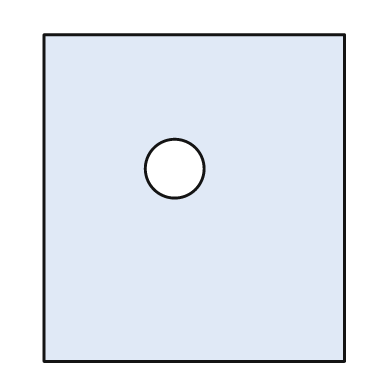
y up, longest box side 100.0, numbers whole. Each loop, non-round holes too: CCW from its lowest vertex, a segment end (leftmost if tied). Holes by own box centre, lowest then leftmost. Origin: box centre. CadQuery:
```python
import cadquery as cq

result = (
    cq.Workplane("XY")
    .moveTo(-46.0, -50.0)
    .lineTo(46.0, -50.0)
    .lineTo(46.0, 50.0)
    .lineTo(-46.0, 50.0)
    .close()
    .moveTo(-6.0, 9.0)
    .circle(9.0)
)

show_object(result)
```